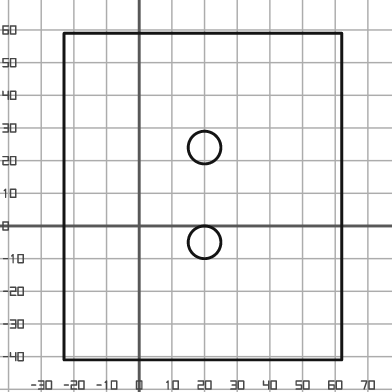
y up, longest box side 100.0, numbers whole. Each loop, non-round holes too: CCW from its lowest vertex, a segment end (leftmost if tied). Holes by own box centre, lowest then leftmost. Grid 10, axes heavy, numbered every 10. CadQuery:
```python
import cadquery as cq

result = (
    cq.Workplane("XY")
    .moveTo(-23.0, -41.0)
    .lineTo(62.0, -41.0)
    .lineTo(62.0, 59.0)
    .lineTo(-23.0, 59.0)
    .close()
    .moveTo(20.0, -5.0)
    .circle(5.0)
    .moveTo(20.0, 24.0)
    .circle(5.0)
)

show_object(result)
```